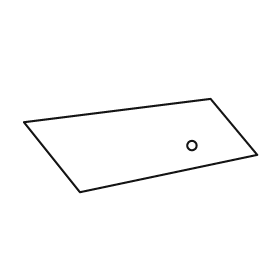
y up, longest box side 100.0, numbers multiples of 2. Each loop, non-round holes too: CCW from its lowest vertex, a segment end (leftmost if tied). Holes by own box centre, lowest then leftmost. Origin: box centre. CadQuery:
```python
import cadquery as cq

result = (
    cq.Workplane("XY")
    .moveTo(-26.0, -20.0)
    .lineTo(50.0, -4.0)
    .lineTo(30.0, 20.0)
    .lineTo(-50.0, 10.0)
    .close()
    .moveTo(22.0, 0.0)
    .circle(2.0)
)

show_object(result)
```